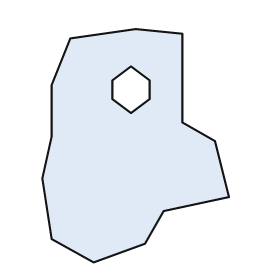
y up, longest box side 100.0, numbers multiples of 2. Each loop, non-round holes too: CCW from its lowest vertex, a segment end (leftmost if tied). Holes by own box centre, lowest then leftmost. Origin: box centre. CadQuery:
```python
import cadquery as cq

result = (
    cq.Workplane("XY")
    .moveTo(-18.0, -50.0)
    .lineTo(4.0, -42.0)
    .lineTo(12.0, -28.0)
    .lineTo(40.0, -22.0)
    .lineTo(34.0, 2.0)
    .lineTo(20.0, 10.0)
    .lineTo(20.0, 48.0)
    .lineTo(0.0, 50.0)
    .lineTo(-28.0, 46.0)
    .lineTo(-36.0, 26.0)
    .lineTo(-36.0, 4.0)
    .lineTo(-40.0, -14.0)
    .lineTo(-36.0, -40.0)
    .close()
    .moveTo(-2.0, 14.0)
    .lineTo(6.0, 20.0)
    .lineTo(6.0, 28.0)
    .lineTo(-2.0, 34.0)
    .lineTo(-10.0, 28.0)
    .lineTo(-10.0, 20.0)
    .close()
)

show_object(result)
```